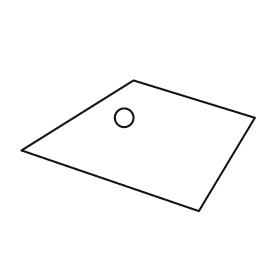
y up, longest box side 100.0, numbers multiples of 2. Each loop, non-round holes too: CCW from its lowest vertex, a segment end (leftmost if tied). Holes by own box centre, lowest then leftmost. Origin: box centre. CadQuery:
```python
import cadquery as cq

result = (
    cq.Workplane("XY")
    .moveTo(26.0, -28.0)
    .lineTo(50.0, 12.0)
    .lineTo(-2.0, 28.0)
    .lineTo(-50.0, -2.0)
    .close()
    .moveTo(-6.0, 12.0)
    .circle(4.0)
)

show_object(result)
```